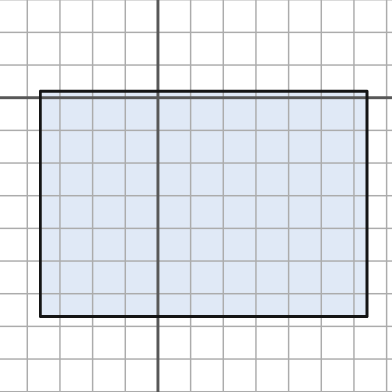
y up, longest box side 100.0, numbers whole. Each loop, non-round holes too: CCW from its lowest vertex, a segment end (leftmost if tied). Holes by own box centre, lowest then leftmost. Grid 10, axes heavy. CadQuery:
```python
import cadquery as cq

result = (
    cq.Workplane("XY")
    .moveTo(-36.0, -67.0)
    .lineTo(64.0, -67.0)
    .lineTo(64.0, 2.0)
    .lineTo(-36.0, 2.0)
    .close()
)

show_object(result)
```